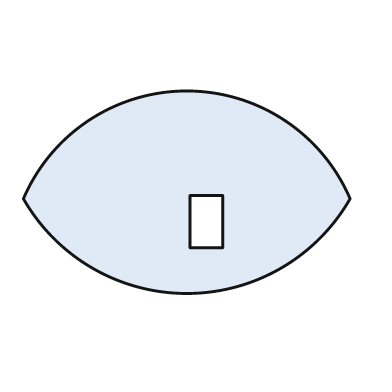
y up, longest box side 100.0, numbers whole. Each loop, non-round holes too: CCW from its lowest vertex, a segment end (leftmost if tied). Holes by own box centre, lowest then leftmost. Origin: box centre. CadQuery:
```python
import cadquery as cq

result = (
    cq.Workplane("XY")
    .moveTo(-50.0, -2.0)
    .threePointArc((0.0, -31.0), (50.0, -2.0))
    .threePointArc((0.0, 31.0), (-50.0, -2.0))
    .close()
    .moveTo(1.0, -17.0)
    .lineTo(11.0, -17.0)
    .lineTo(11.0, -1.0)
    .lineTo(1.0, -1.0)
    .close()
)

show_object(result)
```